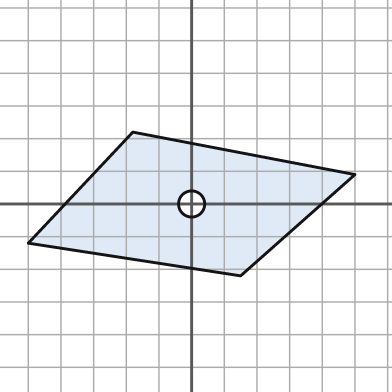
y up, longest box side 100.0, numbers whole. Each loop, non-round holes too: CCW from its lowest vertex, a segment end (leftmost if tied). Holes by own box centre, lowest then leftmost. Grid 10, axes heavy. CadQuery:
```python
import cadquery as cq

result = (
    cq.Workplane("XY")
    .moveTo(15.0, -22.0)
    .lineTo(50.0, 9.0)
    .lineTo(-18.0, 22.0)
    .lineTo(-50.0, -12.0)
    .close()
    .moveTo(0.0, 0.0)
    .circle(4.0)
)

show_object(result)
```